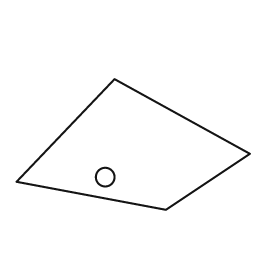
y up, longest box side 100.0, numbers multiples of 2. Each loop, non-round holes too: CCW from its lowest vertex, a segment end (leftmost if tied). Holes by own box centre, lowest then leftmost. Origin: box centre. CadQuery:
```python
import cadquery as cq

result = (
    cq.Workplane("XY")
    .moveTo(14.0, -28.0)
    .lineTo(50.0, -4.0)
    .lineTo(-8.0, 28.0)
    .lineTo(-50.0, -16.0)
    .close()
    .moveTo(-12.0, -14.0)
    .circle(4.0)
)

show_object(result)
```